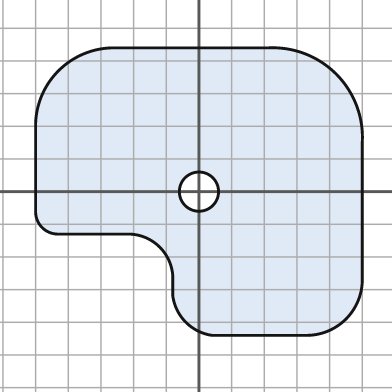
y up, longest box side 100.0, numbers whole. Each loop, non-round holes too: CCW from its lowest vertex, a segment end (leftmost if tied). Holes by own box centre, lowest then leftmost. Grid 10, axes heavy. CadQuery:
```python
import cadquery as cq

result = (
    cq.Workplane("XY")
    .moveTo(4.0, -44.0)
    .lineTo(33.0, -44.0)
    .threePointArc((45.0, -39.0), (50.0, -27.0))
    .lineTo(50.0, 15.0)
    .threePointArc((42.0, 36.0), (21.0, 44.0))
    .lineTo(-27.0, 44.0)
    .threePointArc((-43.0, 37.0), (-50.0, 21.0))
    .lineTo(-50.0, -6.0)
    .threePointArc((-48.0, -11.0), (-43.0, -13.0))
    .lineTo(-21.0, -13.0)
    .threePointArc((-12.0, -17.0), (-8.0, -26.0))
    .lineTo(-8.0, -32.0)
    .threePointArc((-4.0, -40.0), (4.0, -44.0))
    .close()
    .moveTo(0.0, 0.0)
    .circle(6.0)
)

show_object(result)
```